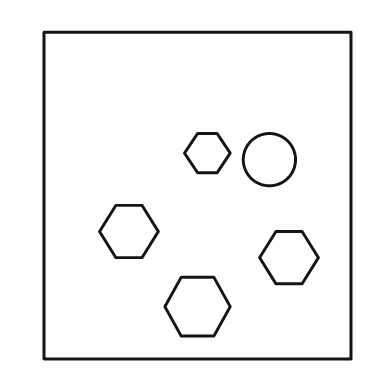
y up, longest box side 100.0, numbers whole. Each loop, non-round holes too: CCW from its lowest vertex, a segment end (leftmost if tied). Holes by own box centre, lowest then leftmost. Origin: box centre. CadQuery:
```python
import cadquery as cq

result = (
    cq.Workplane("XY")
    .moveTo(-47.0, -50.0)
    .lineTo(47.0, -50.0)
    .lineTo(47.0, 50.0)
    .lineTo(-47.0, 50.0)
    .close()
    .moveTo(-5.0, -43.0)
    .lineTo(5.0, -43.0)
    .lineTo(10.0, -34.0)
    .lineTo(5.0, -25.0)
    .lineTo(-5.0, -25.0)
    .lineTo(-10.0, -34.0)
    .close()
    .moveTo(24.0, -27.0)
    .lineTo(32.0, -27.0)
    .lineTo(37.0, -19.0)
    .lineTo(32.0, -11.0)
    .lineTo(24.0, -11.0)
    .lineTo(19.0, -19.0)
    .close()
    .moveTo(-25.0, -19.0)
    .lineTo(-17.0, -19.0)
    .lineTo(-12.0, -11.0)
    .lineTo(-17.0, -3.0)
    .lineTo(-25.0, -3.0)
    .lineTo(-30.0, -11.0)
    .close()
    .moveTo(22.0, 11.0)
    .circle(8.0)
    .moveTo(0.0, 7.0)
    .lineTo(6.0, 7.0)
    .lineTo(10.0, 13.0)
    .lineTo(6.0, 19.0)
    .lineTo(0.0, 19.0)
    .lineTo(-4.0, 13.0)
    .close()
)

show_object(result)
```